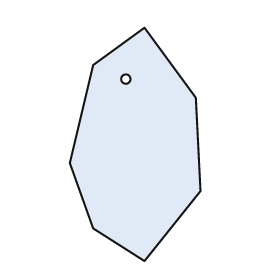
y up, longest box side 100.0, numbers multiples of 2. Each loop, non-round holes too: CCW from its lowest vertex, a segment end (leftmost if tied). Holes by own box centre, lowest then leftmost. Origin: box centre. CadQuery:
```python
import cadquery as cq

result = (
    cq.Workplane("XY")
    .moveTo(4.0, -50.0)
    .lineTo(28.0, -20.0)
    .lineTo(26.0, 20.0)
    .lineTo(4.0, 50.0)
    .lineTo(-18.0, 34.0)
    .lineTo(-28.0, -8.0)
    .lineTo(-18.0, -36.0)
    .close()
    .moveTo(-4.0, 28.0)
    .circle(2.0)
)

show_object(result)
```